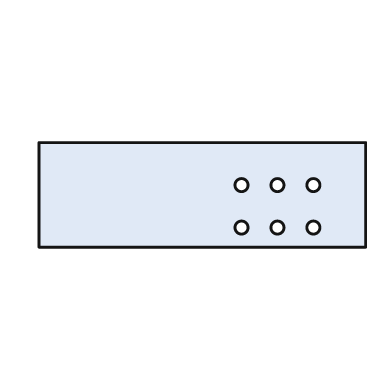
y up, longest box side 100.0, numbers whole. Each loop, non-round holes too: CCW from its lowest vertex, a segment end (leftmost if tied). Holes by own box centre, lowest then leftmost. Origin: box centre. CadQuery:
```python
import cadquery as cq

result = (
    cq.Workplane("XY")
    .moveTo(-50.0, -16.0)
    .lineTo(50.0, -16.0)
    .lineTo(50.0, 16.0)
    .lineTo(-50.0, 16.0)
    .close()
    .moveTo(12.0, -10.0)
    .circle(2.0)
    .moveTo(23.0, -10.0)
    .circle(2.0)
    .moveTo(34.0, -10.0)
    .circle(2.0)
    .moveTo(12.0, 3.0)
    .circle(2.0)
    .moveTo(23.0, 3.0)
    .circle(2.0)
    .moveTo(34.0, 3.0)
    .circle(2.0)
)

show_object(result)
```